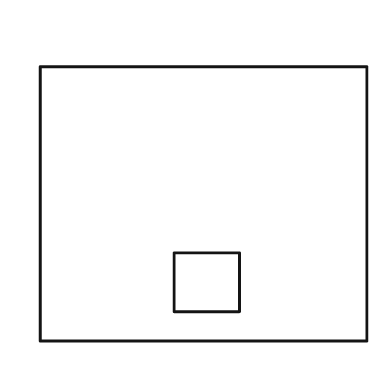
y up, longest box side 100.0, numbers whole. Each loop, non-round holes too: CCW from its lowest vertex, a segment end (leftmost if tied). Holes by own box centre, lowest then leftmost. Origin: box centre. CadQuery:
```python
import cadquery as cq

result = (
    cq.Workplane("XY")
    .moveTo(-50.0, -42.0)
    .lineTo(50.0, -42.0)
    .lineTo(50.0, 42.0)
    .lineTo(-50.0, 42.0)
    .close()
    .moveTo(-9.0, -33.0)
    .lineTo(11.0, -33.0)
    .lineTo(11.0, -15.0)
    .lineTo(-9.0, -15.0)
    .close()
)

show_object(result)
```